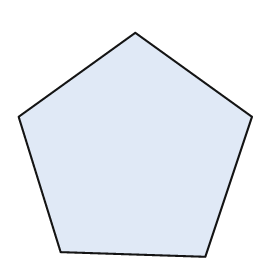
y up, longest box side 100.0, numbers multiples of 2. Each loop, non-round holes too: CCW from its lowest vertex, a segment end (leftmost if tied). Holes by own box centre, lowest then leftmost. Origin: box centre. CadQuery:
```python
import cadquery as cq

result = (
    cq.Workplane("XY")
    .moveTo(30.0, -48.0)
    .lineTo(50.0, 12.0)
    .lineTo(0.0, 48.0)
    .lineTo(-50.0, 12.0)
    .lineTo(-32.0, -46.0)
    .close()
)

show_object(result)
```